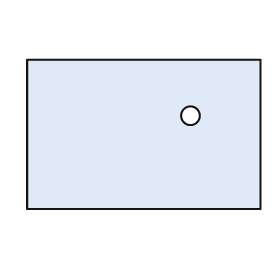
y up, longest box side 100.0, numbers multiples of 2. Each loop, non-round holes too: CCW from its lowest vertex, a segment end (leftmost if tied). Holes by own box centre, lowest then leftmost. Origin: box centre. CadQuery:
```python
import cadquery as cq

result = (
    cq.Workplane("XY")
    .moveTo(-50.0, -32.0)
    .lineTo(50.0, -32.0)
    .lineTo(50.0, 32.0)
    .lineTo(-50.0, 32.0)
    .close()
    .moveTo(20.0, 8.0)
    .circle(4.0)
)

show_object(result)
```